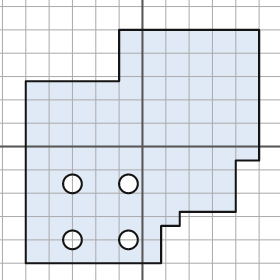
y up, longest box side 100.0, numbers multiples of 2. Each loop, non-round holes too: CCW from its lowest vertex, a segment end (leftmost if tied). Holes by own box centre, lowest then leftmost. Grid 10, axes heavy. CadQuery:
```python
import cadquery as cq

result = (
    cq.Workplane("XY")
    .moveTo(-50.0, -50.0)
    .lineTo(8.0, -50.0)
    .lineTo(8.0, -34.0)
    .lineTo(16.0, -34.0)
    .lineTo(16.0, -28.0)
    .lineTo(40.0, -28.0)
    .lineTo(40.0, -6.0)
    .lineTo(50.0, -6.0)
    .lineTo(50.0, 50.0)
    .lineTo(-10.0, 50.0)
    .lineTo(-10.0, 28.0)
    .lineTo(-50.0, 28.0)
    .close()
    .moveTo(-30.0, -40.0)
    .circle(4.0)
    .moveTo(-6.0, -40.0)
    .circle(4.0)
    .moveTo(-30.0, -16.0)
    .circle(4.0)
    .moveTo(-6.0, -16.0)
    .circle(4.0)
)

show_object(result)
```